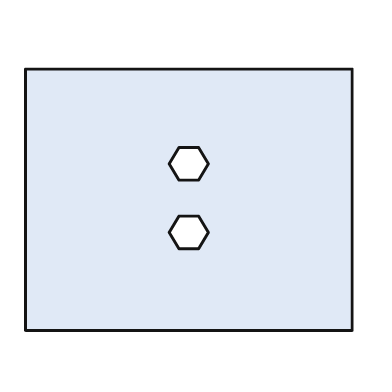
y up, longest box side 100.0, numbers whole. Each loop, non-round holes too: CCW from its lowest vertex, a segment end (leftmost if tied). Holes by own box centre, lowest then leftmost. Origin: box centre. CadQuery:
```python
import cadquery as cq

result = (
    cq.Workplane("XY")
    .moveTo(-50.0, -40.0)
    .lineTo(50.0, -40.0)
    .lineTo(50.0, 40.0)
    .lineTo(-50.0, 40.0)
    .close()
    .moveTo(-3.0, -15.0)
    .lineTo(3.0, -15.0)
    .lineTo(6.0, -10.0)
    .lineTo(3.0, -5.0)
    .lineTo(-3.0, -5.0)
    .lineTo(-6.0, -10.0)
    .close()
    .moveTo(-3.0, 6.0)
    .lineTo(3.0, 6.0)
    .lineTo(6.0, 11.0)
    .lineTo(3.0, 16.0)
    .lineTo(-3.0, 16.0)
    .lineTo(-6.0, 11.0)
    .close()
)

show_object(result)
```